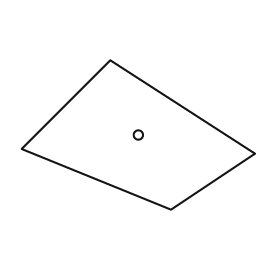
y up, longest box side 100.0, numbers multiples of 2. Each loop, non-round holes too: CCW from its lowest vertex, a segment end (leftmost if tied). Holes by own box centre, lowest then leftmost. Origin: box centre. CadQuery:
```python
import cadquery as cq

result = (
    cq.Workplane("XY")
    .moveTo(14.0, -32.0)
    .lineTo(50.0, -8.0)
    .lineTo(-12.0, 32.0)
    .lineTo(-50.0, -6.0)
    .close()
    .moveTo(0.0, 0.0)
    .circle(2.0)
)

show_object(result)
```